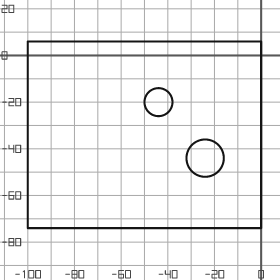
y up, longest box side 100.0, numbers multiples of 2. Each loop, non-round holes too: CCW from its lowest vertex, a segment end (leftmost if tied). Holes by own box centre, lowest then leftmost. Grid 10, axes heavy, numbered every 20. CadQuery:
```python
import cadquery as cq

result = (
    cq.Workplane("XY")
    .moveTo(-100.0, -74.0)
    .lineTo(0.0, -74.0)
    .lineTo(0.0, 6.0)
    .lineTo(-100.0, 6.0)
    .close()
    .moveTo(-24.0, -44.0)
    .circle(8.0)
    .moveTo(-44.0, -20.0)
    .circle(6.0)
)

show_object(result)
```